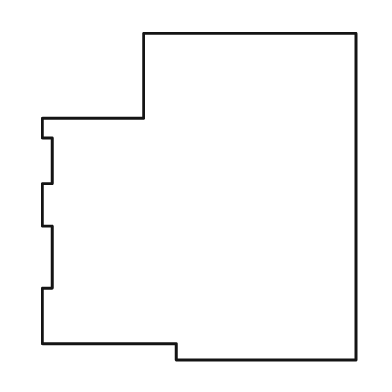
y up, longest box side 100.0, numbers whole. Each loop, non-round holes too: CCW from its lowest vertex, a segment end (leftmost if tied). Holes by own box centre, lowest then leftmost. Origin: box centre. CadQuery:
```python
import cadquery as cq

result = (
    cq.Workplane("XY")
    .moveTo(-7.0, -50.0)
    .lineTo(48.0, -50.0)
    .lineTo(48.0, 50.0)
    .lineTo(-17.0, 50.0)
    .lineTo(-17.0, 24.0)
    .lineTo(-48.0, 24.0)
    .lineTo(-48.0, 18.0)
    .lineTo(-45.0, 18.0)
    .lineTo(-45.0, 4.0)
    .lineTo(-48.0, 4.0)
    .lineTo(-48.0, -9.0)
    .lineTo(-45.0, -9.0)
    .lineTo(-45.0, -28.0)
    .lineTo(-48.0, -28.0)
    .lineTo(-48.0, -45.0)
    .lineTo(-7.0, -45.0)
    .close()
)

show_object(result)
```